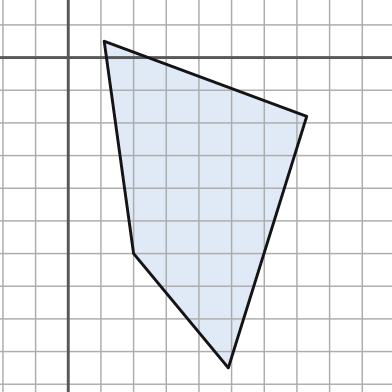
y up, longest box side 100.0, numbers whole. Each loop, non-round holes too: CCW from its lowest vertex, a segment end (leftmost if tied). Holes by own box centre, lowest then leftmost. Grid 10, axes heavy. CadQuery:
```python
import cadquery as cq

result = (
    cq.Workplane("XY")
    .moveTo(49.0, -95.0)
    .lineTo(73.0, -18.0)
    .lineTo(11.0, 5.0)
    .lineTo(20.0, -60.0)
    .close()
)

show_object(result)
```